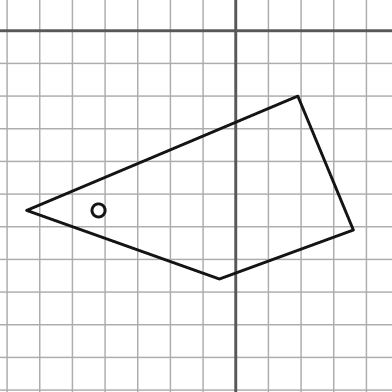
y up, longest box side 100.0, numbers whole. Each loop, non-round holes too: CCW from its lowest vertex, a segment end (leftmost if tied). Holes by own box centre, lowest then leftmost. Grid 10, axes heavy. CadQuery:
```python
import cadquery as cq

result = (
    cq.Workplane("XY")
    .moveTo(-5.0, -76.0)
    .lineTo(36.0, -61.0)
    .lineTo(19.0, -20.0)
    .lineTo(-64.0, -55.0)
    .close()
    .moveTo(-42.0, -55.0)
    .circle(2.0)
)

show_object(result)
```